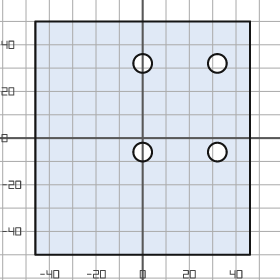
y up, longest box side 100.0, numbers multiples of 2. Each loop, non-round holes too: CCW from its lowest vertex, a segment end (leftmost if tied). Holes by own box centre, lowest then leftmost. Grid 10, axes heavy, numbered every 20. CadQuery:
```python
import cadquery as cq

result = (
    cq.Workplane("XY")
    .moveTo(-46.0, -50.0)
    .lineTo(46.0, -50.0)
    .lineTo(46.0, 50.0)
    .lineTo(-46.0, 50.0)
    .close()
    .moveTo(0.0, -6.0)
    .circle(4.0)
    .moveTo(32.0, -6.0)
    .circle(4.0)
    .moveTo(0.0, 32.0)
    .circle(4.0)
    .moveTo(32.0, 32.0)
    .circle(4.0)
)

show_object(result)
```